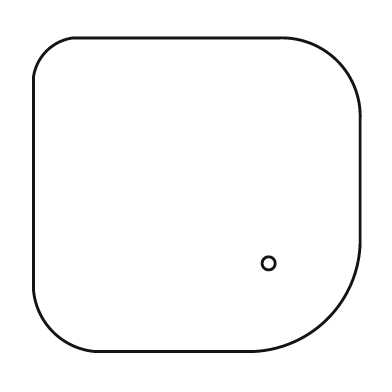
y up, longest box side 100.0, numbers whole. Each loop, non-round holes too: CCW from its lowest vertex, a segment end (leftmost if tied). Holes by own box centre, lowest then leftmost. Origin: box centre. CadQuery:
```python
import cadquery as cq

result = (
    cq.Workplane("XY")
    .moveTo(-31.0, -48.0)
    .lineTo(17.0, -48.0)
    .threePointArc((40.0, -38.0), (50.0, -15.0))
    .lineTo(50.0, 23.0)
    .threePointArc((43.0, 41.0), (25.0, 48.0))
    .lineTo(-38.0, 48.0)
    .threePointArc((-46.0, 44.0), (-50.0, 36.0))
    .lineTo(-50.0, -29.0)
    .threePointArc((-44.0, -42.0), (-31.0, -48.0))
    .close()
    .moveTo(22.0, -21.0)
    .circle(2.0)
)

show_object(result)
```